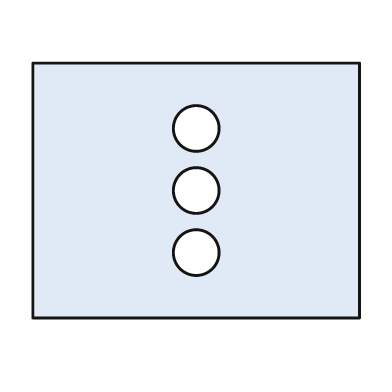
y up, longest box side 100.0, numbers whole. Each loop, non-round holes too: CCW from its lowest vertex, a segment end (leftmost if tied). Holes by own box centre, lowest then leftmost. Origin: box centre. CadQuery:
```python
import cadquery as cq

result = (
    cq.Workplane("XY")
    .moveTo(-50.0, -39.0)
    .lineTo(50.0, -39.0)
    .lineTo(50.0, 39.0)
    .lineTo(-50.0, 39.0)
    .close()
    .moveTo(0.0, -19.0)
    .circle(7.0)
    .moveTo(0.0, 0.0)
    .circle(7.0)
    .moveTo(0.0, 19.0)
    .circle(7.0)
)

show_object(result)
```